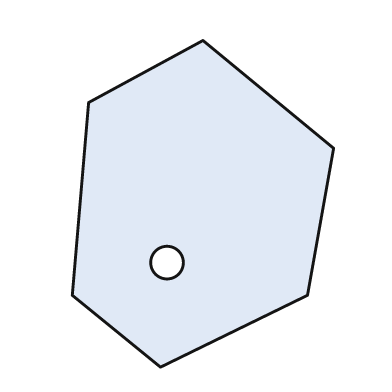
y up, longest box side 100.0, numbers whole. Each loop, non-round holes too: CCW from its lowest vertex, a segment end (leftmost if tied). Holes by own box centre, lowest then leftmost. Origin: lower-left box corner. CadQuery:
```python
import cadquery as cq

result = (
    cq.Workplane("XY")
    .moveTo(27.0, 0.0)
    .lineTo(72.0, 22.0)
    .lineTo(80.0, 67.0)
    .lineTo(40.0, 100.0)
    .lineTo(5.0, 81.0)
    .lineTo(0.0, 22.0)
    .close()
    .moveTo(29.0, 32.0)
    .circle(5.0)
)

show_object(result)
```